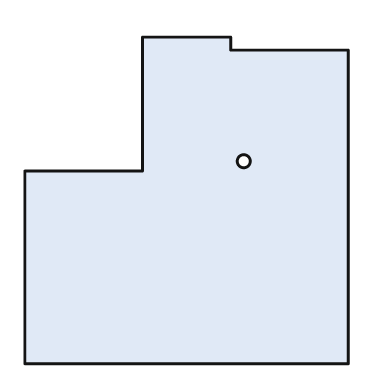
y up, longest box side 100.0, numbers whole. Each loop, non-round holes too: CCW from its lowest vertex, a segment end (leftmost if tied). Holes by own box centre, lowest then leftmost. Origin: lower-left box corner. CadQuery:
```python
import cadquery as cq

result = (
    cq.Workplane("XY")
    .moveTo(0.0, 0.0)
    .lineTo(99.0, 0.0)
    .lineTo(99.0, 96.0)
    .lineTo(63.0, 96.0)
    .lineTo(63.0, 100.0)
    .lineTo(36.0, 100.0)
    .lineTo(36.0, 59.0)
    .lineTo(0.0, 59.0)
    .close()
    .moveTo(67.0, 62.0)
    .circle(2.0)
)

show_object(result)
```